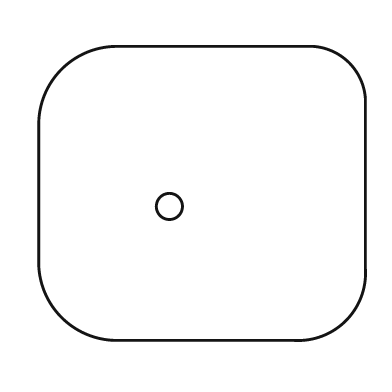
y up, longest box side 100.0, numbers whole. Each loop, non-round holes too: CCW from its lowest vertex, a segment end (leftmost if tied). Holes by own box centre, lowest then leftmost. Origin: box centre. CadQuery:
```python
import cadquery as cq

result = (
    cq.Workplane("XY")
    .moveTo(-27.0, -45.0)
    .lineTo(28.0, -45.0)
    .threePointArc((44.0, -39.0), (50.0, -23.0))
    .lineTo(50.0, 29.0)
    .threePointArc((45.0, 40.0), (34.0, 45.0))
    .lineTo(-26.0, 45.0)
    .threePointArc((-43.0, 38.0), (-50.0, 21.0))
    .lineTo(-50.0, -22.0)
    .threePointArc((-43.0, -38.0), (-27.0, -45.0))
    .close()
    .moveTo(-10.0, -4.0)
    .circle(4.0)
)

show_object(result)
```